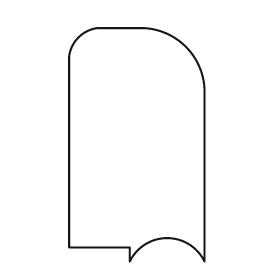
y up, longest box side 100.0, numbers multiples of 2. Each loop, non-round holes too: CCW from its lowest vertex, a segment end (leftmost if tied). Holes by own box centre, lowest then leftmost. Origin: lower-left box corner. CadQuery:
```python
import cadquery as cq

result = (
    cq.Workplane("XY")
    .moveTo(26.0, 0.0)
    .threePointArc((42.0, 10.0), (58.0, 0.0))
    .lineTo(58.0, 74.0)
    .threePointArc((50.0, 92.0), (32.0, 100.0))
    .lineTo(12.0, 100.0)
    .threePointArc((4.0, 96.0), (0.0, 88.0))
    .lineTo(0.0, 6.0)
    .lineTo(26.0, 6.0)
    .close()
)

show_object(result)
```